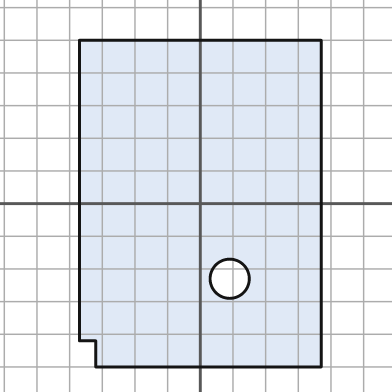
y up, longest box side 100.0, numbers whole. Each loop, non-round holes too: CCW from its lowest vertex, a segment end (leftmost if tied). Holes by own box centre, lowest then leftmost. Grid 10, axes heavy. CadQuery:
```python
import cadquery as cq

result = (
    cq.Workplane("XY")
    .moveTo(-32.0, -50.0)
    .lineTo(37.0, -50.0)
    .lineTo(37.0, 50.0)
    .lineTo(-37.0, 50.0)
    .lineTo(-37.0, -42.0)
    .lineTo(-32.0, -42.0)
    .close()
    .moveTo(9.0, -23.0)
    .circle(6.0)
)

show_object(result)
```